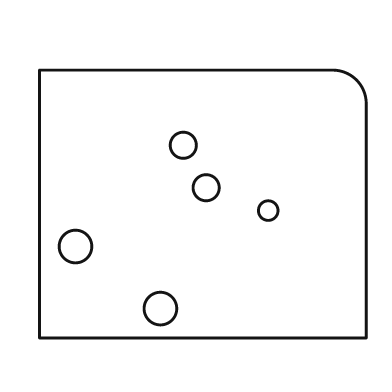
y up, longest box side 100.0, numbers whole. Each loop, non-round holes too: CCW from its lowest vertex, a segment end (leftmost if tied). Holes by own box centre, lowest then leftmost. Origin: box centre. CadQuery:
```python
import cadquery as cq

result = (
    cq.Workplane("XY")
    .moveTo(-50.0, -41.0)
    .lineTo(50.0, -41.0)
    .lineTo(50.0, 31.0)
    .threePointArc((47.0, 38.0), (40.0, 41.0))
    .lineTo(-50.0, 41.0)
    .close()
    .moveTo(-13.0, -32.0)
    .circle(5.0)
    .moveTo(-39.0, -13.0)
    .circle(5.0)
    .moveTo(20.0, -2.0)
    .circle(3.0)
    .moveTo(1.0, 5.0)
    .circle(4.0)
    .moveTo(-6.0, 18.0)
    .circle(4.0)
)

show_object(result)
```